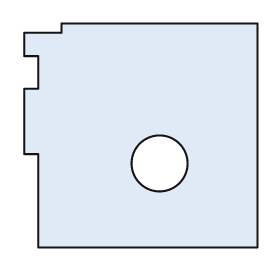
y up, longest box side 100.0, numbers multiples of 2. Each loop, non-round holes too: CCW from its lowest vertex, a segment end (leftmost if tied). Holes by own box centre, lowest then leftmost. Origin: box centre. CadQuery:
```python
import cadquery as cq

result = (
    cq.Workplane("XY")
    .moveTo(-44.0, -48.0)
    .lineTo(50.0, -48.0)
    .lineTo(50.0, 48.0)
    .lineTo(-34.0, 48.0)
    .lineTo(-34.0, 44.0)
    .lineTo(-50.0, 44.0)
    .lineTo(-50.0, 34.0)
    .lineTo(-44.0, 34.0)
    .lineTo(-44.0, 20.0)
    .lineTo(-50.0, 20.0)
    .lineTo(-50.0, -8.0)
    .lineTo(-44.0, -8.0)
    .close()
    .moveTo(8.0, -12.0)
    .circle(12.0)
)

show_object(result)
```